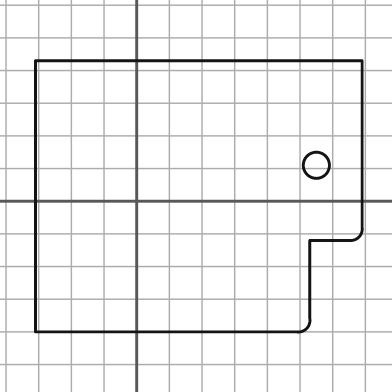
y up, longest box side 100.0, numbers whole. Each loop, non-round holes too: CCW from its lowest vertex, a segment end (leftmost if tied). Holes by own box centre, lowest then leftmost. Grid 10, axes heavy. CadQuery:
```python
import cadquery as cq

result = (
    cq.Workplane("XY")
    .moveTo(-31.0, -40.0)
    .lineTo(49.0, -40.0)
    .threePointArc((52.0, -39.0), (53.0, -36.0))
    .lineTo(53.0, -12.0)
    .lineTo(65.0, -12.0)
    .threePointArc((68.0, -11.0), (69.0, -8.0))
    .lineTo(69.0, 43.0)
    .lineTo(-31.0, 43.0)
    .close()
    .moveTo(55.0, 11.0)
    .circle(4.0)
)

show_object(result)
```